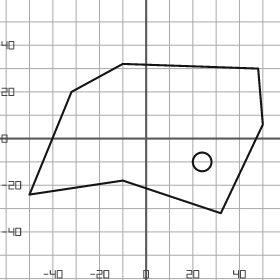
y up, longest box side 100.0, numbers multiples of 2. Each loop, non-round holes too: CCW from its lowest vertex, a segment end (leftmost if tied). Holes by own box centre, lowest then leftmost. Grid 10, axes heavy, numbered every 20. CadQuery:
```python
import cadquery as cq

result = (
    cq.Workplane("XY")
    .moveTo(32.0, -32.0)
    .lineTo(50.0, 6.0)
    .lineTo(48.0, 30.0)
    .lineTo(-10.0, 32.0)
    .lineTo(-32.0, 20.0)
    .lineTo(-50.0, -24.0)
    .lineTo(-10.0, -18.0)
    .close()
    .moveTo(24.0, -10.0)
    .circle(4.0)
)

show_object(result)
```